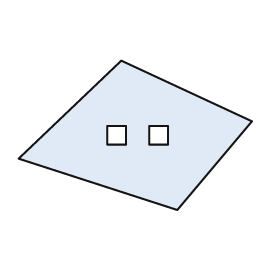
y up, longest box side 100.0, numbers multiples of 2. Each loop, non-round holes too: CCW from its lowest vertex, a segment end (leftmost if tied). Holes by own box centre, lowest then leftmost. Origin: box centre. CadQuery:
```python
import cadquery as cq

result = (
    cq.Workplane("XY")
    .moveTo(18.0, -32.0)
    .lineTo(50.0, 6.0)
    .lineTo(-6.0, 32.0)
    .lineTo(-50.0, -10.0)
    .close()
    .moveTo(-12.0, -4.0)
    .lineTo(-4.0, -4.0)
    .lineTo(-4.0, 4.0)
    .lineTo(-12.0, 4.0)
    .close()
    .moveTo(6.0, -4.0)
    .lineTo(14.0, -4.0)
    .lineTo(14.0, 4.0)
    .lineTo(6.0, 4.0)
    .close()
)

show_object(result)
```